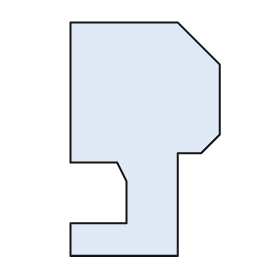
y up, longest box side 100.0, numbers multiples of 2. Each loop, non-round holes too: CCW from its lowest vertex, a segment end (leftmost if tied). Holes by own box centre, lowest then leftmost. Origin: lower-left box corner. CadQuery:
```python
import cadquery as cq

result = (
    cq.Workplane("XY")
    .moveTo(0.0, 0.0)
    .lineTo(46.0, 0.0)
    .lineTo(46.0, 44.0)
    .lineTo(56.0, 44.0)
    .lineTo(64.0, 52.0)
    .lineTo(64.0, 82.0)
    .lineTo(46.0, 100.0)
    .lineTo(0.0, 100.0)
    .lineTo(0.0, 40.0)
    .lineTo(20.0, 40.0)
    .lineTo(24.0, 32.0)
    .lineTo(24.0, 14.0)
    .lineTo(0.0, 14.0)
    .close()
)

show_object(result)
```